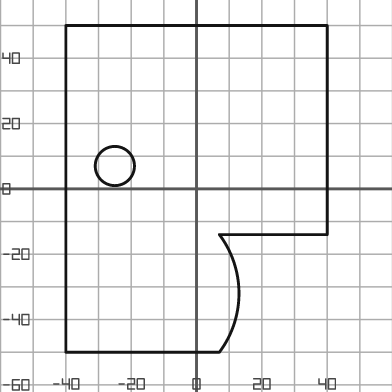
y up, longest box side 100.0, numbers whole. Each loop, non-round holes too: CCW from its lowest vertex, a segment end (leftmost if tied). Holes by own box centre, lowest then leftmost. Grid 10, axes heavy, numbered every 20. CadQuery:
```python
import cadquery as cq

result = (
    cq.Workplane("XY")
    .moveTo(-40.0, -50.0)
    .lineTo(7.0, -50.0)
    .threePointArc((13.0, -32.0), (7.0, -14.0))
    .lineTo(40.0, -14.0)
    .lineTo(40.0, 50.0)
    .lineTo(-40.0, 50.0)
    .close()
    .moveTo(-25.0, 7.0)
    .circle(6.0)
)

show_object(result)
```